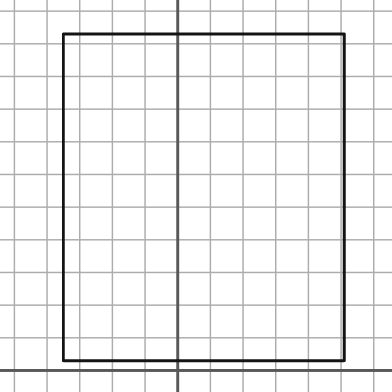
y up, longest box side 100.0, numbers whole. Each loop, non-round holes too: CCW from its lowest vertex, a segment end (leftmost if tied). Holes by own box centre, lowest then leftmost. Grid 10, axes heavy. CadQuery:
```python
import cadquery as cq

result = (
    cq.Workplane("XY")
    .moveTo(-35.0, 3.0)
    .lineTo(51.0, 3.0)
    .lineTo(51.0, 103.0)
    .lineTo(-35.0, 103.0)
    .close()
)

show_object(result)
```